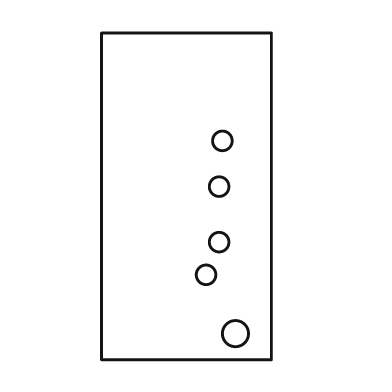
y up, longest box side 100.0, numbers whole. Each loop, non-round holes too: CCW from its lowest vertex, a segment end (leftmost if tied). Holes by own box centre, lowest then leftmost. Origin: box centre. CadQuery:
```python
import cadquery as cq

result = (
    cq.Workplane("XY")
    .moveTo(-26.0, -50.0)
    .lineTo(26.0, -50.0)
    .lineTo(26.0, 50.0)
    .lineTo(-26.0, 50.0)
    .close()
    .moveTo(15.0, -42.0)
    .circle(4.0)
    .moveTo(6.0, -24.0)
    .circle(3.0)
    .moveTo(10.0, -14.0)
    .circle(3.0)
    .moveTo(10.0, 3.0)
    .circle(3.0)
    .moveTo(11.0, 17.0)
    .circle(3.0)
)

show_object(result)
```